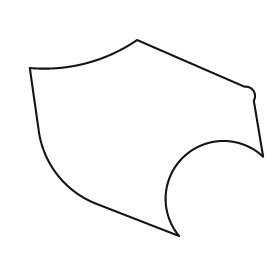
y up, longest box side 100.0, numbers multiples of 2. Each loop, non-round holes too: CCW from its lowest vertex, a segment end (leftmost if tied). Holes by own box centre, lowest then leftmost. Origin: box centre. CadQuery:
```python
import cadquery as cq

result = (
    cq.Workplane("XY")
    .moveTo(14.0, -42.0)
    .threePointArc((16.0, -8.0), (50.0, -8.0))
    .lineTo(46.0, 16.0)
    .threePointArc((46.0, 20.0), (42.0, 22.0))
    .lineTo(-4.0, 42.0)
    .threePointArc((-26.0, 32.0), (-50.0, 30.0))
    .lineTo(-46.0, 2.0)
    .threePointArc((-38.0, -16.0), (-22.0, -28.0))
    .close()
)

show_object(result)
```